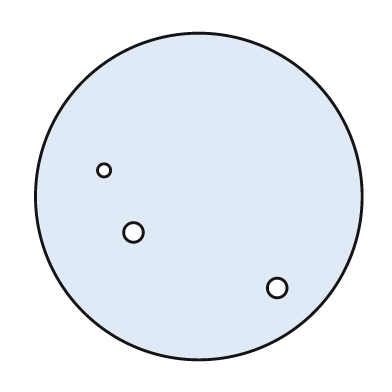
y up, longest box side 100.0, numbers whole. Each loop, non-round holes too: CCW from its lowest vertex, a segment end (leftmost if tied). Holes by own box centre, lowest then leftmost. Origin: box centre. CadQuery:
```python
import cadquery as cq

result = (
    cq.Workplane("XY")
    .moveTo(0.0, 0.0)
    .circle(50.0)
    .moveTo(24.0, -28.0)
    .circle(3.0)
    .moveTo(-20.0, -11.0)
    .circle(3.0)
    .moveTo(-29.0, 8.0)
    .circle(2.0)
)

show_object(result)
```